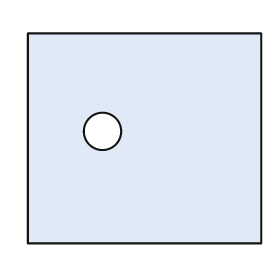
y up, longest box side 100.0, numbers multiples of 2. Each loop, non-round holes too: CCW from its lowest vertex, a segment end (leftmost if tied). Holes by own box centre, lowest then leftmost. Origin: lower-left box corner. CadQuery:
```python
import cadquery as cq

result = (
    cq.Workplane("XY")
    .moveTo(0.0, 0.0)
    .lineTo(100.0, 0.0)
    .lineTo(100.0, 90.0)
    .lineTo(0.0, 90.0)
    .close()
    .moveTo(32.0, 48.0)
    .circle(8.0)
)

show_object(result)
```